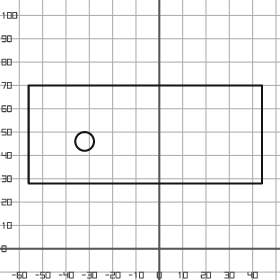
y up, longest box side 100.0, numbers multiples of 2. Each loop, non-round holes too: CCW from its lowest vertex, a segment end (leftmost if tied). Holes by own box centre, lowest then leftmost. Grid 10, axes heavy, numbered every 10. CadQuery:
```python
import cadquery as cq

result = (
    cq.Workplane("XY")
    .moveTo(-56.0, 28.0)
    .lineTo(44.0, 28.0)
    .lineTo(44.0, 70.0)
    .lineTo(-56.0, 70.0)
    .close()
    .moveTo(-32.0, 46.0)
    .circle(4.0)
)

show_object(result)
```